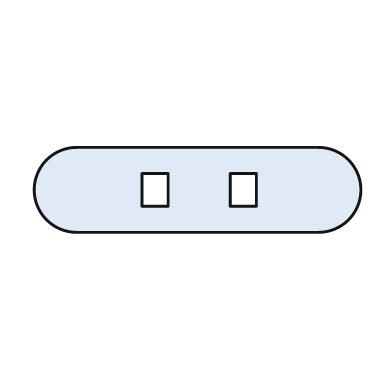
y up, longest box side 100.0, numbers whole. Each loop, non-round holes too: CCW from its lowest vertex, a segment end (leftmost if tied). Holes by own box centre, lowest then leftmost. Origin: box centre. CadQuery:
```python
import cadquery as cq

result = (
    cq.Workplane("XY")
    .moveTo(-37.0, -13.0)
    .lineTo(37.0, -13.0)
    .threePointArc((50.0, 0.0), (37.0, 13.0))
    .lineTo(-37.0, 13.0)
    .threePointArc((-50.0, 0.0), (-37.0, -13.0))
    .close()
    .moveTo(-17.0, -5.0)
    .lineTo(-9.0, -5.0)
    .lineTo(-9.0, 5.0)
    .lineTo(-17.0, 5.0)
    .close()
    .moveTo(10.0, -5.0)
    .lineTo(18.0, -5.0)
    .lineTo(18.0, 5.0)
    .lineTo(10.0, 5.0)
    .close()
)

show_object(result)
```